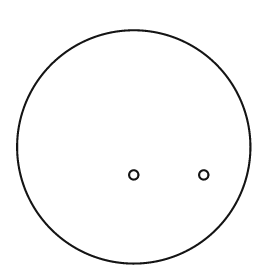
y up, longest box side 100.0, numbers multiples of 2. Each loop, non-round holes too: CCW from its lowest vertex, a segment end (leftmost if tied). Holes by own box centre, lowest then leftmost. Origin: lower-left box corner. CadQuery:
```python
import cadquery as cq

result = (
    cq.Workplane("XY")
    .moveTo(50.0, 50.0)
    .circle(50.0)
    .moveTo(50.0, 38.0)
    .circle(2.0)
    .moveTo(80.0, 38.0)
    .circle(2.0)
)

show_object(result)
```